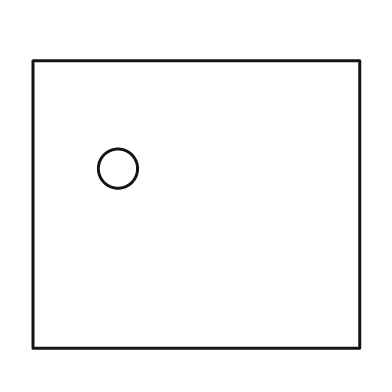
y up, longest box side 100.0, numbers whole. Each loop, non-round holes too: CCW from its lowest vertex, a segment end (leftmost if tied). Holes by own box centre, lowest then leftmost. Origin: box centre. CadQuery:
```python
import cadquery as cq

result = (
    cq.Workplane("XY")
    .moveTo(-50.0, -44.0)
    .lineTo(50.0, -44.0)
    .lineTo(50.0, 44.0)
    .lineTo(-50.0, 44.0)
    .close()
    .moveTo(-24.0, 11.0)
    .circle(6.0)
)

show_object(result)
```